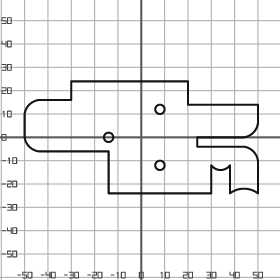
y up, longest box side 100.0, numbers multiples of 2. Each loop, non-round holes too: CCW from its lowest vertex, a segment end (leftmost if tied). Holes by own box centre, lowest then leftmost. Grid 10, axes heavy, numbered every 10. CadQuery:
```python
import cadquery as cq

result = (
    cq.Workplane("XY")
    .moveTo(-14.0, -24.0)
    .lineTo(30.0, -24.0)
    .lineTo(30.0, -12.0)
    .threePointArc((34.0, -14.0), (38.0, -12.0))
    .lineTo(38.0, -24.0)
    .threePointArc((44.0, -22.0), (50.0, -24.0))
    .lineTo(50.0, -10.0)
    .threePointArc((48.0, -6.0), (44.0, -4.0))
    .lineTo(24.0, -4.0)
    .lineTo(24.0, 0.0)
    .lineTo(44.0, 0.0)
    .threePointArc((48.0, 2.0), (50.0, 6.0))
    .lineTo(50.0, 14.0)
    .lineTo(20.0, 14.0)
    .lineTo(20.0, 24.0)
    .lineTo(-30.0, 24.0)
    .lineTo(-30.0, 16.0)
    .lineTo(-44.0, 16.0)
    .threePointArc((-48.0, 14.0), (-50.0, 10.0))
    .lineTo(-50.0, 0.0)
    .threePointArc((-48.0, -4.0), (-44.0, -6.0))
    .lineTo(-14.0, -6.0)
    .close()
    .moveTo(8.0, -12.0)
    .circle(2.0)
    .moveTo(-14.0, 0.0)
    .circle(2.0)
    .moveTo(8.0, 12.0)
    .circle(2.0)
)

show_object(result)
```